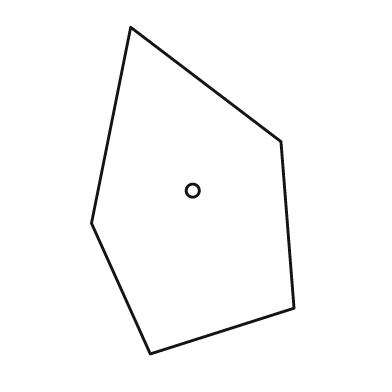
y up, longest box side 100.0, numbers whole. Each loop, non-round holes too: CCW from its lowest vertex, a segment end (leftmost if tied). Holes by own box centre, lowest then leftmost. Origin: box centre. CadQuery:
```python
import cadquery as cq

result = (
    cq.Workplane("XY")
    .moveTo(-13.0, -50.0)
    .lineTo(31.0, -36.0)
    .lineTo(27.0, 15.0)
    .lineTo(-19.0, 50.0)
    .lineTo(-31.0, -10.0)
    .close()
    .moveTo(0.0, 0.0)
    .circle(2.0)
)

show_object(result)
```